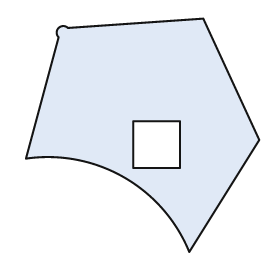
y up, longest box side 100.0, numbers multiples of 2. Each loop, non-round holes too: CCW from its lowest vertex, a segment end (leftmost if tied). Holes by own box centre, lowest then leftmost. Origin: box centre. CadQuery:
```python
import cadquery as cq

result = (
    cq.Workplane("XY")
    .moveTo(20.0, -50.0)
    .lineTo(50.0, -2.0)
    .lineTo(26.0, 50.0)
    .lineTo(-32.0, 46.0)
    .threePointArc((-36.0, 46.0), (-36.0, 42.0))
    .lineTo(-50.0, -10.0)
    .threePointArc((-8.0, -18.0), (20.0, -50.0))
    .close()
    .moveTo(-4.0, -14.0)
    .lineTo(16.0, -14.0)
    .lineTo(16.0, 6.0)
    .lineTo(-4.0, 6.0)
    .close()
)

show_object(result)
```